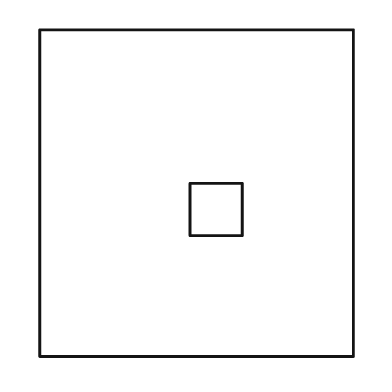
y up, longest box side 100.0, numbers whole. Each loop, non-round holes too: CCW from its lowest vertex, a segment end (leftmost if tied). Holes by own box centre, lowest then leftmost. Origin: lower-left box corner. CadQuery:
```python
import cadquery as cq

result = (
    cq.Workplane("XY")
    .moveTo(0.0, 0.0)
    .lineTo(96.0, 0.0)
    .lineTo(96.0, 100.0)
    .lineTo(0.0, 100.0)
    .close()
    .moveTo(46.0, 37.0)
    .lineTo(62.0, 37.0)
    .lineTo(62.0, 53.0)
    .lineTo(46.0, 53.0)
    .close()
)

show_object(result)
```